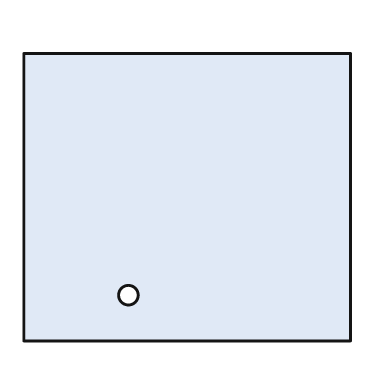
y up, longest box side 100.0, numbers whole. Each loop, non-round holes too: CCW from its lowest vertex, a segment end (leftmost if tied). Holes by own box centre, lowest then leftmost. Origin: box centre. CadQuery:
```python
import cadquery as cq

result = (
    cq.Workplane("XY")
    .moveTo(-50.0, -44.0)
    .lineTo(50.0, -44.0)
    .lineTo(50.0, 44.0)
    .lineTo(-50.0, 44.0)
    .close()
    .moveTo(-18.0, -30.0)
    .circle(3.0)
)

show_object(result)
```